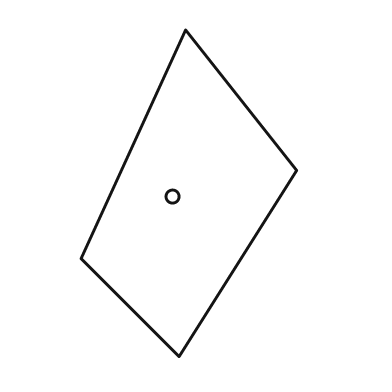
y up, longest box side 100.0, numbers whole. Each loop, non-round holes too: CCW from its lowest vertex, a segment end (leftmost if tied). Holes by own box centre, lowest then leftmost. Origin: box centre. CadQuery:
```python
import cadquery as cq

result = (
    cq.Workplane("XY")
    .moveTo(-3.0, -50.0)
    .lineTo(33.0, 7.0)
    .lineTo(-1.0, 50.0)
    .lineTo(-33.0, -20.0)
    .close()
    .moveTo(-5.0, -1.0)
    .circle(2.0)
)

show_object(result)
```